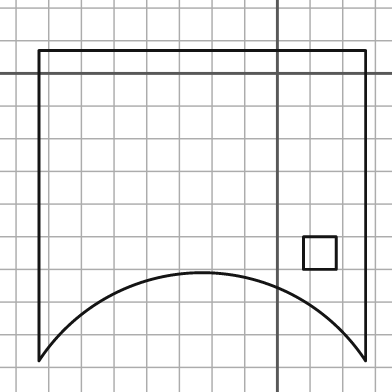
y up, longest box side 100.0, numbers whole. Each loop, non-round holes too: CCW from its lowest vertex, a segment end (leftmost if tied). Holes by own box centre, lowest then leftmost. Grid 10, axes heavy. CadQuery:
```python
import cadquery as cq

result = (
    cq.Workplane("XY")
    .moveTo(-73.0, -88.0)
    .threePointArc((-23.0, -61.0), (27.0, -88.0))
    .lineTo(27.0, 7.0)
    .lineTo(-73.0, 7.0)
    .close()
    .moveTo(8.0, -60.0)
    .lineTo(18.0, -60.0)
    .lineTo(18.0, -50.0)
    .lineTo(8.0, -50.0)
    .close()
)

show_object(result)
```